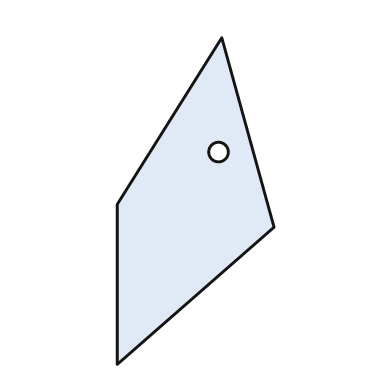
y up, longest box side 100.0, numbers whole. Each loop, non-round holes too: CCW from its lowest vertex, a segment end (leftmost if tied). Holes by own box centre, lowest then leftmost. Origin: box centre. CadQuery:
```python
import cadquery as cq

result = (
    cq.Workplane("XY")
    .moveTo(-24.0, -50.0)
    .lineTo(24.0, -8.0)
    .lineTo(8.0, 50.0)
    .lineTo(-24.0, -1.0)
    .close()
    .moveTo(7.0, 15.0)
    .circle(3.0)
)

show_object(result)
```